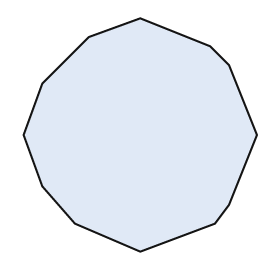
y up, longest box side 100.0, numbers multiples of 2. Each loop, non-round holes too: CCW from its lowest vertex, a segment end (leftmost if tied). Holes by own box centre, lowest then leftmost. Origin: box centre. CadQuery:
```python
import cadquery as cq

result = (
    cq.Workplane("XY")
    .moveTo(0.0, -50.0)
    .lineTo(32.0, -38.0)
    .lineTo(38.0, -30.0)
    .lineTo(50.0, 0.0)
    .lineTo(38.0, 30.0)
    .lineTo(30.0, 38.0)
    .lineTo(0.0, 50.0)
    .lineTo(-22.0, 42.0)
    .lineTo(-42.0, 22.0)
    .lineTo(-50.0, 0.0)
    .lineTo(-42.0, -22.0)
    .lineTo(-28.0, -38.0)
    .close()
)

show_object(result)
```